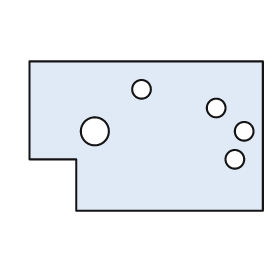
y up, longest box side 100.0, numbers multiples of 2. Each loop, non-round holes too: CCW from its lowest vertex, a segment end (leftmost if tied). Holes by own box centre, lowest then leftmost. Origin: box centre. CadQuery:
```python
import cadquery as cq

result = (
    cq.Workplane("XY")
    .moveTo(-30.0, -32.0)
    .lineTo(50.0, -32.0)
    .lineTo(50.0, 32.0)
    .lineTo(-50.0, 32.0)
    .lineTo(-50.0, -10.0)
    .lineTo(-30.0, -10.0)
    .close()
    .moveTo(38.0, -10.0)
    .circle(4.0)
    .moveTo(-22.0, 2.0)
    .circle(6.0)
    .moveTo(42.0, 2.0)
    .circle(4.0)
    .moveTo(30.0, 12.0)
    .circle(4.0)
    .moveTo(-2.0, 20.0)
    .circle(4.0)
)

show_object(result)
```